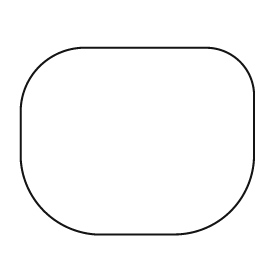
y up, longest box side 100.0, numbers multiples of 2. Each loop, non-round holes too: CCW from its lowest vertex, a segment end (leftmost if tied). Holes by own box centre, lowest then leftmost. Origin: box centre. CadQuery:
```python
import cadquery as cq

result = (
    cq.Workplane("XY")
    .moveTo(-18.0, -40.0)
    .lineTo(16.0, -40.0)
    .threePointArc((40.0, -30.0), (50.0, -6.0))
    .lineTo(50.0, 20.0)
    .threePointArc((44.0, 34.0), (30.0, 40.0))
    .lineTo(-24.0, 40.0)
    .threePointArc((-42.0, 32.0), (-50.0, 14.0))
    .lineTo(-50.0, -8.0)
    .threePointArc((-40.0, -30.0), (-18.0, -40.0))
    .close()
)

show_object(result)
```